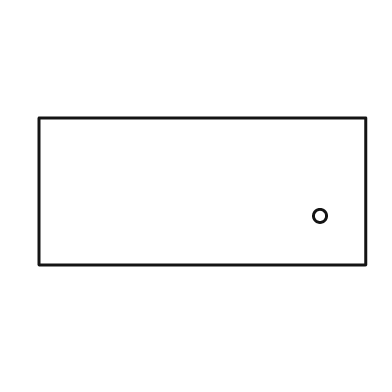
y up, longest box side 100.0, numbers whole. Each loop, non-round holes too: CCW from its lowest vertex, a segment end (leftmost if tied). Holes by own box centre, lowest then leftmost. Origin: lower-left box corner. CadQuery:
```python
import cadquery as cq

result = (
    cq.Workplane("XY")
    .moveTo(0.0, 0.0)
    .lineTo(100.0, 0.0)
    .lineTo(100.0, 45.0)
    .lineTo(0.0, 45.0)
    .close()
    .moveTo(86.0, 15.0)
    .circle(2.0)
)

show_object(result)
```